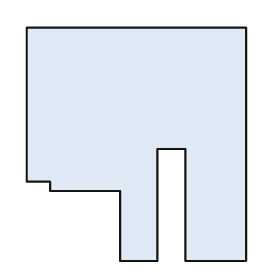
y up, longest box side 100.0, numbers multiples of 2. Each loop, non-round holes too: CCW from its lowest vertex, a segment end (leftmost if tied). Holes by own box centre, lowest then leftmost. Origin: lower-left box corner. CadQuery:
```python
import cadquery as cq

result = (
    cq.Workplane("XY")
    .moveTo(40.0, 0.0)
    .lineTo(56.0, 0.0)
    .lineTo(56.0, 48.0)
    .lineTo(68.0, 48.0)
    .lineTo(68.0, 0.0)
    .lineTo(94.0, 0.0)
    .lineTo(94.0, 100.0)
    .lineTo(0.0, 100.0)
    .lineTo(0.0, 34.0)
    .lineTo(10.0, 34.0)
    .lineTo(10.0, 30.0)
    .lineTo(40.0, 30.0)
    .close()
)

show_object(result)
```